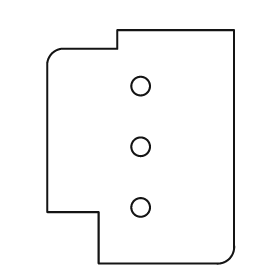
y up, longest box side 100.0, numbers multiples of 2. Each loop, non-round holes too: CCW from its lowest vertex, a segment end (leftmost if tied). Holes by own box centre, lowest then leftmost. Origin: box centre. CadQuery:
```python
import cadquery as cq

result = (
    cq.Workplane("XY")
    .moveTo(-18.0, -50.0)
    .lineTo(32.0, -50.0)
    .threePointArc((38.0, -48.0), (40.0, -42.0))
    .lineTo(40.0, 50.0)
    .lineTo(-10.0, 50.0)
    .lineTo(-10.0, 42.0)
    .lineTo(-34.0, 42.0)
    .threePointArc((-38.0, 40.0), (-40.0, 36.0))
    .lineTo(-40.0, -28.0)
    .lineTo(-18.0, -28.0)
    .close()
    .moveTo(0.0, -26.0)
    .circle(4.0)
    .moveTo(0.0, 0.0)
    .circle(4.0)
    .moveTo(0.0, 26.0)
    .circle(4.0)
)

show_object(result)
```